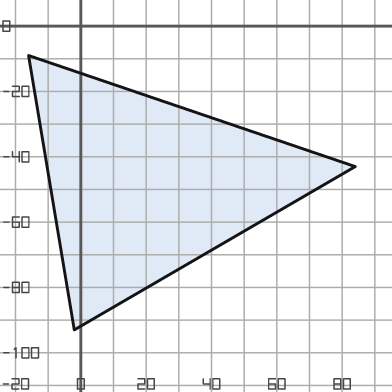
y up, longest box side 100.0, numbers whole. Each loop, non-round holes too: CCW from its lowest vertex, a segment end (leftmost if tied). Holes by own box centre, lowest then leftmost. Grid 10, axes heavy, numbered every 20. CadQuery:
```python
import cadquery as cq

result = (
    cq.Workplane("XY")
    .moveTo(-2.0, -93.0)
    .lineTo(84.0, -43.0)
    .lineTo(-16.0, -9.0)
    .close()
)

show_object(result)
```